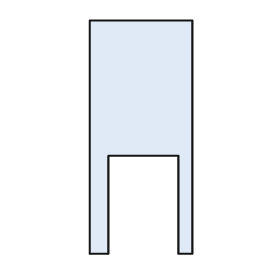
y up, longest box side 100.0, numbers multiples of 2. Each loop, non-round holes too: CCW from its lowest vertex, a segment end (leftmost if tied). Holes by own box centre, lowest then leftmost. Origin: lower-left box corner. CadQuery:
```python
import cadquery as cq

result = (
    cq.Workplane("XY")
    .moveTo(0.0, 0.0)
    .lineTo(8.0, 0.0)
    .lineTo(8.0, 42.0)
    .lineTo(38.0, 42.0)
    .lineTo(38.0, 0.0)
    .lineTo(44.0, 0.0)
    .lineTo(44.0, 100.0)
    .lineTo(0.0, 100.0)
    .close()
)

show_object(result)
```